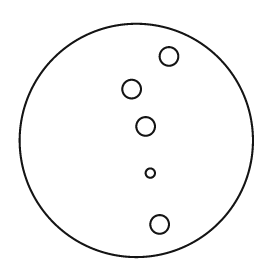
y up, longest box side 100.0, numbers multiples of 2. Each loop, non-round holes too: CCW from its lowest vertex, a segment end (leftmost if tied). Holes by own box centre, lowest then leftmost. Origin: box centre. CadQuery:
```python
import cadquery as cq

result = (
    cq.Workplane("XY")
    .moveTo(0.0, 0.0)
    .circle(50.0)
    .moveTo(10.0, -36.0)
    .circle(4.0)
    .moveTo(6.0, -14.0)
    .circle(2.0)
    .moveTo(4.0, 6.0)
    .circle(4.0)
    .moveTo(-2.0, 22.0)
    .circle(4.0)
    .moveTo(14.0, 36.0)
    .circle(4.0)
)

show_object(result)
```